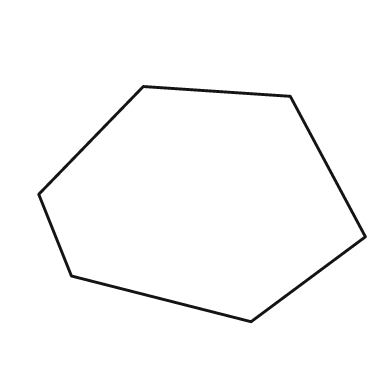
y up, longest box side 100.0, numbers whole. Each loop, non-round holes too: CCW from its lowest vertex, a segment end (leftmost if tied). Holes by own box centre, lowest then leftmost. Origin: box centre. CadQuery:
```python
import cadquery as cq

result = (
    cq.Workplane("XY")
    .moveTo(15.0, -36.0)
    .lineTo(50.0, -10.0)
    .lineTo(27.0, 33.0)
    .lineTo(-18.0, 36.0)
    .lineTo(-50.0, 3.0)
    .lineTo(-40.0, -22.0)
    .close()
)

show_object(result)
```